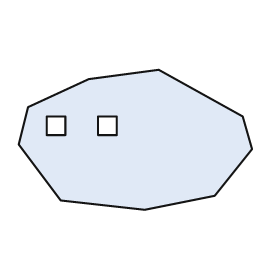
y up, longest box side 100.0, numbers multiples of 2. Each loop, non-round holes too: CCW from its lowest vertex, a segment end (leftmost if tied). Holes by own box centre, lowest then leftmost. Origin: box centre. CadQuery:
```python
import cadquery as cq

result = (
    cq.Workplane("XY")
    .moveTo(4.0, -30.0)
    .lineTo(34.0, -24.0)
    .lineTo(50.0, -4.0)
    .lineTo(46.0, 10.0)
    .lineTo(10.0, 30.0)
    .lineTo(-20.0, 26.0)
    .lineTo(-46.0, 14.0)
    .lineTo(-50.0, -2.0)
    .lineTo(-32.0, -26.0)
    .close()
    .moveTo(-38.0, 2.0)
    .lineTo(-30.0, 2.0)
    .lineTo(-30.0, 10.0)
    .lineTo(-38.0, 10.0)
    .close()
    .moveTo(-16.0, 2.0)
    .lineTo(-8.0, 2.0)
    .lineTo(-8.0, 10.0)
    .lineTo(-16.0, 10.0)
    .close()
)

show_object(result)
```